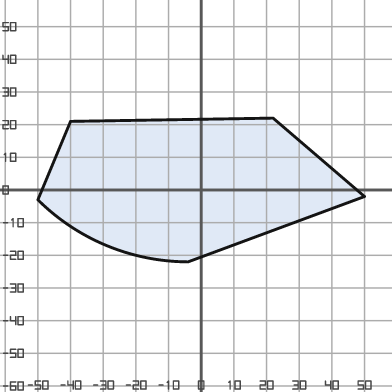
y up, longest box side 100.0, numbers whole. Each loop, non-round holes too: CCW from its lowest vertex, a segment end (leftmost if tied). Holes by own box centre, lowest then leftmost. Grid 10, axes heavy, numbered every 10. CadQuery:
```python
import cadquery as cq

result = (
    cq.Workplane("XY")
    .moveTo(-4.0, -22.0)
    .lineTo(50.0, -2.0)
    .lineTo(22.0, 22.0)
    .lineTo(-40.0, 21.0)
    .lineTo(-50.0, -3.0)
    .threePointArc((-29.0, -17.0), (-4.0, -22.0))
    .close()
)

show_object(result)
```